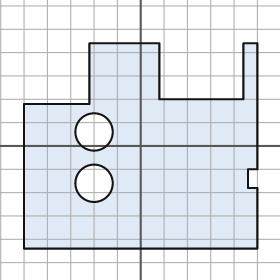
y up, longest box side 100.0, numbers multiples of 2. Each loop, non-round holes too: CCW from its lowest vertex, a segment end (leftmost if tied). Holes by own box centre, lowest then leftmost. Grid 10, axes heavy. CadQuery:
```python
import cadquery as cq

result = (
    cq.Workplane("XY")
    .moveTo(-50.0, -44.0)
    .lineTo(50.0, -44.0)
    .lineTo(50.0, -18.0)
    .lineTo(46.0, -18.0)
    .lineTo(46.0, -10.0)
    .lineTo(50.0, -10.0)
    .lineTo(50.0, 44.0)
    .lineTo(44.0, 44.0)
    .lineTo(44.0, 20.0)
    .lineTo(8.0, 20.0)
    .lineTo(8.0, 44.0)
    .lineTo(-22.0, 44.0)
    .lineTo(-22.0, 18.0)
    .lineTo(-50.0, 18.0)
    .close()
    .moveTo(-20.0, -16.0)
    .circle(8.0)
    .moveTo(-20.0, 6.0)
    .circle(8.0)
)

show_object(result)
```